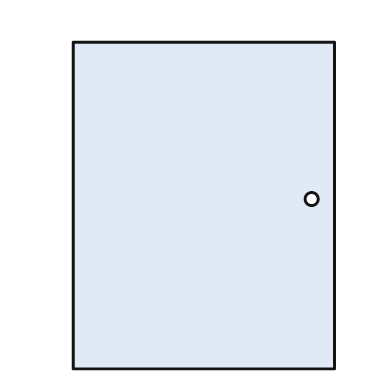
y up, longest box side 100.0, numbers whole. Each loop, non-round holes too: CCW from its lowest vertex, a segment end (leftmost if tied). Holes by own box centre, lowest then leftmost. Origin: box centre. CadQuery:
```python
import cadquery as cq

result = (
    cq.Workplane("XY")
    .moveTo(-40.0, -50.0)
    .lineTo(40.0, -50.0)
    .lineTo(40.0, 50.0)
    .lineTo(-40.0, 50.0)
    .close()
    .moveTo(33.0, 2.0)
    .circle(2.0)
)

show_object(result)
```